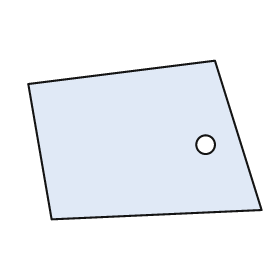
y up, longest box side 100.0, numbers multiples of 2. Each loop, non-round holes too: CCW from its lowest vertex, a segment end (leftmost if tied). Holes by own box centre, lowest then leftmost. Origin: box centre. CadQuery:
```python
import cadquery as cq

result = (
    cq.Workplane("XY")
    .moveTo(-40.0, -34.0)
    .lineTo(50.0, -30.0)
    .lineTo(30.0, 34.0)
    .lineTo(-50.0, 24.0)
    .close()
    .moveTo(26.0, -2.0)
    .circle(4.0)
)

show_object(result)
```